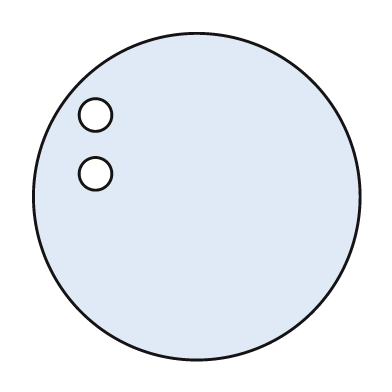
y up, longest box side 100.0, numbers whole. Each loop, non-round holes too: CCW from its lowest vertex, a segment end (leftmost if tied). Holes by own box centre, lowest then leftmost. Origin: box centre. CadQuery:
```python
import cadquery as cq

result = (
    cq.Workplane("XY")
    .moveTo(0.0, 0.0)
    .circle(50.0)
    .moveTo(-31.0, 7.0)
    .circle(5.0)
    .moveTo(-31.0, 25.0)
    .circle(5.0)
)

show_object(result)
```